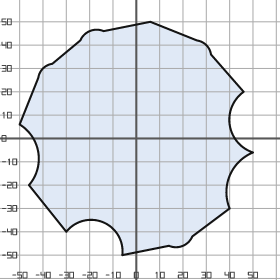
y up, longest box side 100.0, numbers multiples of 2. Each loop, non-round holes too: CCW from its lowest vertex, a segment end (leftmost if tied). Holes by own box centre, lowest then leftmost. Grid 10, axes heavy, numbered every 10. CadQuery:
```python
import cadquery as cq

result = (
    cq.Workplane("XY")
    .moveTo(-6.0, -50.0)
    .lineTo(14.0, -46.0)
    .threePointArc((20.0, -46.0), (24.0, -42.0))
    .lineTo(40.0, -30.0)
    .threePointArc((40.0, -16.0), (50.0, -6.0))
    .threePointArc((40.0, 6.0), (46.0, 20.0))
    .lineTo(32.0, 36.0)
    .threePointArc((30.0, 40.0), (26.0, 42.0))
    .lineTo(6.0, 50.0)
    .lineTo(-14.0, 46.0)
    .threePointArc((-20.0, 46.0), (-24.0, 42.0))
    .lineTo(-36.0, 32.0)
    .threePointArc((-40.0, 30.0), (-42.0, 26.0))
    .lineTo(-50.0, 6.0)
    .threePointArc((-42.0, -6.0), (-46.0, -20.0))
    .lineTo(-30.0, -40.0)
    .threePointArc((-14.0, -36.0), (-6.0, -50.0))
    .close()
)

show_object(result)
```